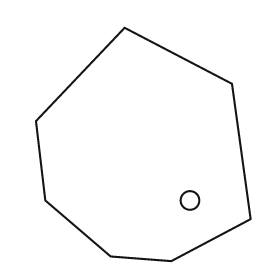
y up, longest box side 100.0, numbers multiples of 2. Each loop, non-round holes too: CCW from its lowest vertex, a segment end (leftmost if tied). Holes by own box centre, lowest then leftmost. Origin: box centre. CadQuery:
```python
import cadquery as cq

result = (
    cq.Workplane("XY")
    .moveTo(12.0, -50.0)
    .lineTo(46.0, -32.0)
    .lineTo(38.0, 26.0)
    .lineTo(-8.0, 50.0)
    .lineTo(-46.0, 10.0)
    .lineTo(-42.0, -24.0)
    .lineTo(-14.0, -48.0)
    .close()
    .moveTo(20.0, -24.0)
    .circle(4.0)
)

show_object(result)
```